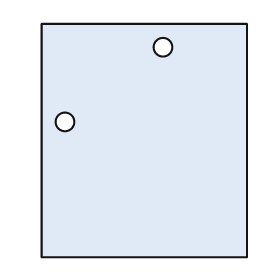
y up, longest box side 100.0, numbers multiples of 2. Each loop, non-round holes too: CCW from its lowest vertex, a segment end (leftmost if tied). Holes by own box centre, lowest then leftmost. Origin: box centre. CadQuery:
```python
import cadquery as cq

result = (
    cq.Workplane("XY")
    .moveTo(-44.0, -50.0)
    .lineTo(44.0, -50.0)
    .lineTo(44.0, 50.0)
    .lineTo(-44.0, 50.0)
    .close()
    .moveTo(-34.0, 8.0)
    .circle(4.0)
    .moveTo(8.0, 40.0)
    .circle(4.0)
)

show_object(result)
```